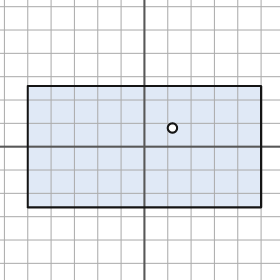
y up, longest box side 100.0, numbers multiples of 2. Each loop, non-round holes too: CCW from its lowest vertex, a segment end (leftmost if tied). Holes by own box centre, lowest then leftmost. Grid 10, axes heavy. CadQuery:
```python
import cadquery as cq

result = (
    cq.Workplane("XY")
    .moveTo(-50.0, -26.0)
    .lineTo(50.0, -26.0)
    .lineTo(50.0, 26.0)
    .lineTo(-50.0, 26.0)
    .close()
    .moveTo(12.0, 8.0)
    .circle(2.0)
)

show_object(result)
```